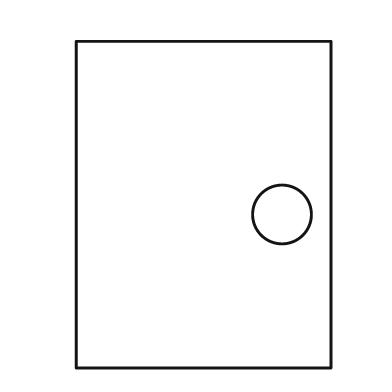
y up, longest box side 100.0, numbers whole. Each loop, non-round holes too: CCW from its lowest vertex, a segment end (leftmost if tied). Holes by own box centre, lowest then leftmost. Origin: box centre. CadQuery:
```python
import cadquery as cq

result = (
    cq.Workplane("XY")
    .moveTo(-39.0, -50.0)
    .lineTo(39.0, -50.0)
    .lineTo(39.0, 50.0)
    .lineTo(-39.0, 50.0)
    .close()
    .moveTo(24.0, -3.0)
    .circle(9.0)
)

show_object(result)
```